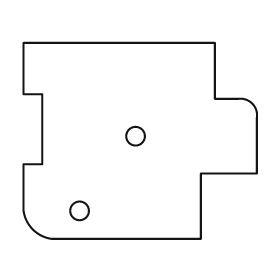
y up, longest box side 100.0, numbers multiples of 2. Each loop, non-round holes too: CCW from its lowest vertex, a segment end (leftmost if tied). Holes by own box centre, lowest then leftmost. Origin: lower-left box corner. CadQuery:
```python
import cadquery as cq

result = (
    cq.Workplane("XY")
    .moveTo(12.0, 0.0)
    .lineTo(76.0, 0.0)
    .lineTo(76.0, 28.0)
    .lineTo(100.0, 28.0)
    .lineTo(100.0, 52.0)
    .threePointArc((98.0, 58.0), (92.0, 60.0))
    .lineTo(82.0, 60.0)
    .lineTo(82.0, 84.0)
    .lineTo(0.0, 84.0)
    .lineTo(0.0, 62.0)
    .lineTo(8.0, 62.0)
    .lineTo(8.0, 32.0)
    .lineTo(0.0, 32.0)
    .lineTo(0.0, 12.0)
    .threePointArc((4.0, 4.0), (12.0, 0.0))
    .close()
    .moveTo(24.0, 12.0)
    .circle(4.0)
    .moveTo(48.0, 44.0)
    .circle(4.0)
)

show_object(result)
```